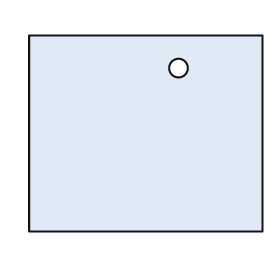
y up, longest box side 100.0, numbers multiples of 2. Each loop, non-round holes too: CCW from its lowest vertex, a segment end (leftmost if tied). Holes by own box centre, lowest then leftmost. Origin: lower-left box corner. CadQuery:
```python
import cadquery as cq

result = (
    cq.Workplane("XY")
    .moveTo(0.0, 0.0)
    .lineTo(100.0, 0.0)
    .lineTo(100.0, 84.0)
    .lineTo(0.0, 84.0)
    .close()
    .moveTo(64.0, 70.0)
    .circle(4.0)
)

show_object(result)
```